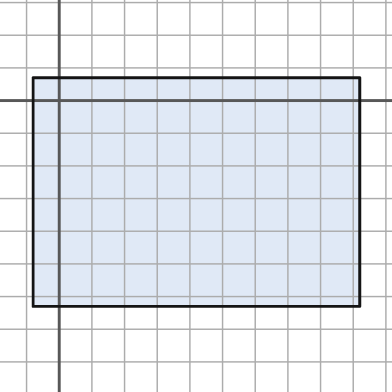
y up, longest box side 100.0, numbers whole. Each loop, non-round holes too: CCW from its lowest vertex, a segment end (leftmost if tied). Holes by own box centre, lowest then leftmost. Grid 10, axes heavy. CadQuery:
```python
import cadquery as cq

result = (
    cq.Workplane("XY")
    .moveTo(-8.0, -63.0)
    .lineTo(92.0, -63.0)
    .lineTo(92.0, 7.0)
    .lineTo(-8.0, 7.0)
    .close()
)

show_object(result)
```